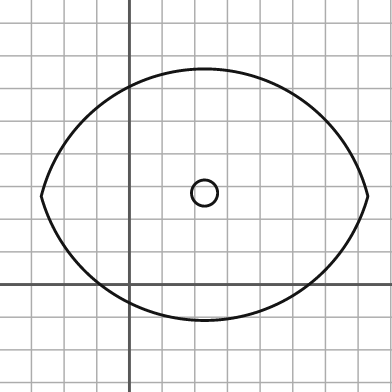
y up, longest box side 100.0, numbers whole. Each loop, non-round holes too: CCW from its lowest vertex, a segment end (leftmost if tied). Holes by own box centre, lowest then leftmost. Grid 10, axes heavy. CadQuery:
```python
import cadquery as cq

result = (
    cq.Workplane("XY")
    .moveTo(-27.0, 27.0)
    .threePointArc((23.0, -11.0), (73.0, 27.0))
    .threePointArc((23.0, 66.0), (-27.0, 27.0))
    .close()
    .moveTo(23.0, 28.0)
    .circle(4.0)
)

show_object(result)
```